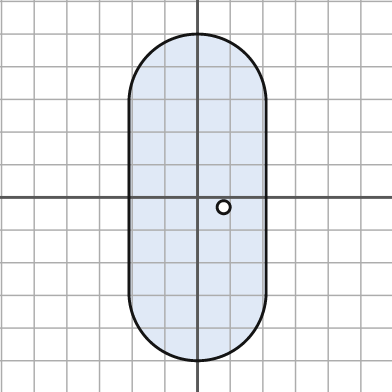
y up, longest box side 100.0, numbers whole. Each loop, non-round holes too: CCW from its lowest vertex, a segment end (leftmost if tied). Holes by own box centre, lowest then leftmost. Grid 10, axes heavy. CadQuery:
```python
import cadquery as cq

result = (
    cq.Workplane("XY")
    .moveTo(-21.0, -29.0)
    .threePointArc((0.0, -50.0), (21.0, -29.0))
    .lineTo(21.0, 29.0)
    .threePointArc((0.0, 50.0), (-21.0, 29.0))
    .close()
    .moveTo(8.0, -3.0)
    .circle(2.0)
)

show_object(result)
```